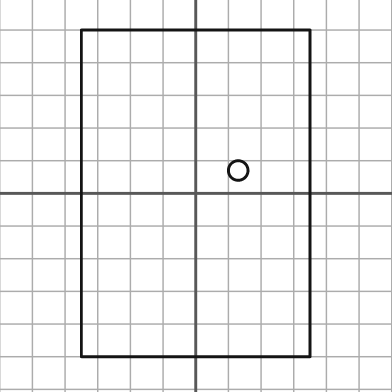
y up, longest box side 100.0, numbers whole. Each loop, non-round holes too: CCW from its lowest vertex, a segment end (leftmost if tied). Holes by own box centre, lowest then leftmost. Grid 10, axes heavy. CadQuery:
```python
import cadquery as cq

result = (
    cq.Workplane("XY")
    .moveTo(-35.0, -50.0)
    .lineTo(35.0, -50.0)
    .lineTo(35.0, 50.0)
    .lineTo(-35.0, 50.0)
    .close()
    .moveTo(13.0, 7.0)
    .circle(3.0)
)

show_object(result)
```